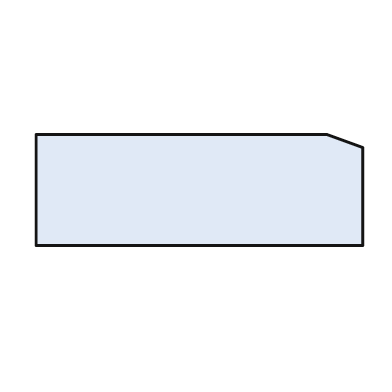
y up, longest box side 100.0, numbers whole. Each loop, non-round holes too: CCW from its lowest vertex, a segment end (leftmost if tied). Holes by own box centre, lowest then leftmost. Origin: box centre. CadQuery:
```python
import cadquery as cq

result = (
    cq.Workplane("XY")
    .moveTo(-50.0, -17.0)
    .lineTo(50.0, -17.0)
    .lineTo(50.0, 13.0)
    .lineTo(39.0, 17.0)
    .lineTo(-50.0, 17.0)
    .close()
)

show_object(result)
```